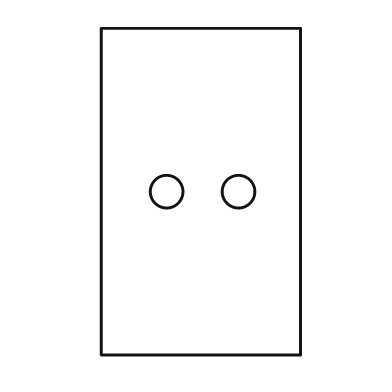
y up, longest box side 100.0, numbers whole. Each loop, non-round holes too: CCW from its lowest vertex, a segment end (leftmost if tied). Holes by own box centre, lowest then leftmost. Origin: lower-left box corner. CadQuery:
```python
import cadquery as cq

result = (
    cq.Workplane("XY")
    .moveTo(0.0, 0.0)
    .lineTo(61.0, 0.0)
    .lineTo(61.0, 100.0)
    .lineTo(0.0, 100.0)
    .close()
    .moveTo(20.0, 50.0)
    .circle(5.0)
    .moveTo(42.0, 50.0)
    .circle(5.0)
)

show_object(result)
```